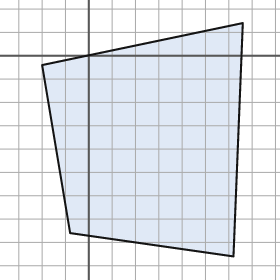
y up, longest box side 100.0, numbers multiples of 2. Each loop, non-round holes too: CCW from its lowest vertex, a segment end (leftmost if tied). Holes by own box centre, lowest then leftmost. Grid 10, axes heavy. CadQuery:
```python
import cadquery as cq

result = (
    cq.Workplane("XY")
    .moveTo(62.0, -86.0)
    .lineTo(66.0, 14.0)
    .lineTo(-20.0, -4.0)
    .lineTo(-8.0, -76.0)
    .close()
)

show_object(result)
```